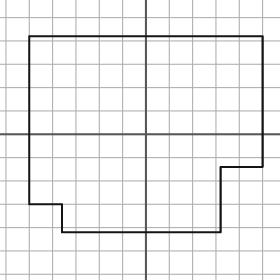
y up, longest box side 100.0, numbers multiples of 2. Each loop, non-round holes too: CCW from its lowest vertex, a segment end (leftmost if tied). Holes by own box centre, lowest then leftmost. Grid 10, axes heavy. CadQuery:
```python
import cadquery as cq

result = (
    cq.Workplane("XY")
    .moveTo(-36.0, -42.0)
    .lineTo(32.0, -42.0)
    .lineTo(32.0, -14.0)
    .lineTo(50.0, -14.0)
    .lineTo(50.0, 42.0)
    .lineTo(-50.0, 42.0)
    .lineTo(-50.0, -30.0)
    .lineTo(-36.0, -30.0)
    .close()
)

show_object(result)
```